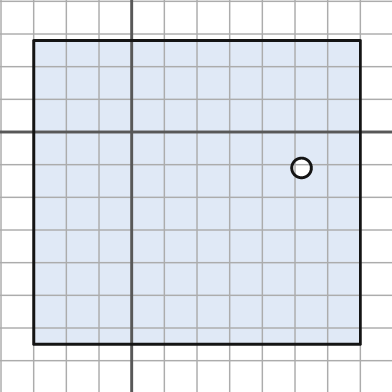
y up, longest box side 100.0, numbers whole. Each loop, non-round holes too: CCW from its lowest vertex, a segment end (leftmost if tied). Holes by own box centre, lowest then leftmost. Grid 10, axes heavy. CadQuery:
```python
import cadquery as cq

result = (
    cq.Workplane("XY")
    .moveTo(-30.0, -65.0)
    .lineTo(70.0, -65.0)
    .lineTo(70.0, 28.0)
    .lineTo(-30.0, 28.0)
    .close()
    .moveTo(52.0, -11.0)
    .circle(3.0)
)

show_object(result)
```